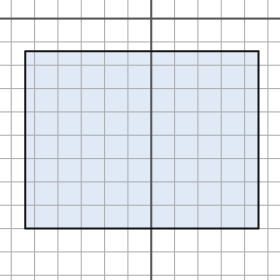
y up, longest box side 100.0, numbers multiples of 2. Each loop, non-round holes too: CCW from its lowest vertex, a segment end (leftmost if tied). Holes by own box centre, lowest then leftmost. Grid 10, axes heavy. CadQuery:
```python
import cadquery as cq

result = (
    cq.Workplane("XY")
    .moveTo(-54.0, -90.0)
    .lineTo(46.0, -90.0)
    .lineTo(46.0, -14.0)
    .lineTo(-54.0, -14.0)
    .close()
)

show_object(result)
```